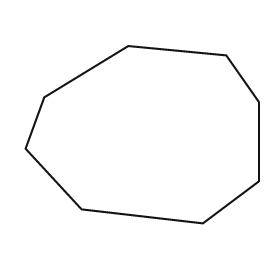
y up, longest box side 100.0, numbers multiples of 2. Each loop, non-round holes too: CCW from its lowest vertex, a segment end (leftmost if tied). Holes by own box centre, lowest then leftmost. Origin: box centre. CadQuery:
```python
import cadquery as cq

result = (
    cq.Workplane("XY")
    .moveTo(26.0, -38.0)
    .lineTo(50.0, -20.0)
    .lineTo(50.0, 14.0)
    .lineTo(36.0, 34.0)
    .lineTo(-6.0, 38.0)
    .lineTo(-42.0, 16.0)
    .lineTo(-50.0, -6.0)
    .lineTo(-26.0, -32.0)
    .close()
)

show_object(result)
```